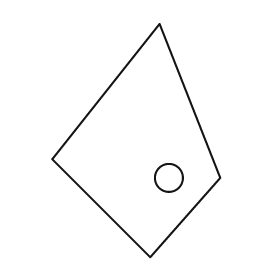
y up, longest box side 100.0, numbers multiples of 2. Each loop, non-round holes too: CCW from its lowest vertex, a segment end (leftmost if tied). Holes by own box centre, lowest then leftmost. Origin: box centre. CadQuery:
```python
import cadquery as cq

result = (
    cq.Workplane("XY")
    .moveTo(6.0, -50.0)
    .lineTo(36.0, -16.0)
    .lineTo(10.0, 50.0)
    .lineTo(-36.0, -8.0)
    .close()
    .moveTo(14.0, -16.0)
    .circle(6.0)
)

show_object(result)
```